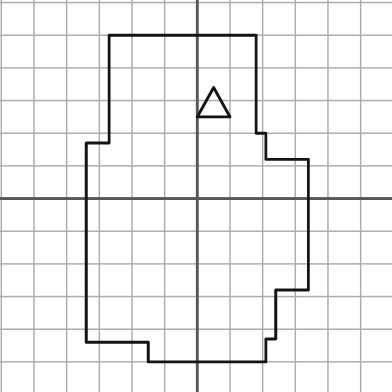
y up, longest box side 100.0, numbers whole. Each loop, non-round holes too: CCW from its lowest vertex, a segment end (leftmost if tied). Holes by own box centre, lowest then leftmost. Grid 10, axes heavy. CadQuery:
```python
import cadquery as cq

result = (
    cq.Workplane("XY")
    .moveTo(-15.0, -50.0)
    .lineTo(21.0, -50.0)
    .lineTo(21.0, -43.0)
    .lineTo(24.0, -43.0)
    .lineTo(24.0, -28.0)
    .lineTo(34.0, -28.0)
    .lineTo(34.0, 12.0)
    .lineTo(21.0, 12.0)
    .lineTo(21.0, 20.0)
    .lineTo(18.0, 20.0)
    .lineTo(18.0, 50.0)
    .lineTo(-27.0, 50.0)
    .lineTo(-27.0, 17.0)
    .lineTo(-34.0, 17.0)
    .lineTo(-34.0, -44.0)
    .lineTo(-15.0, -44.0)
    .close()
    .moveTo(0.0, 25.0)
    .lineTo(10.0, 25.0)
    .lineTo(5.0, 34.0)
    .close()
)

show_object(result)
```